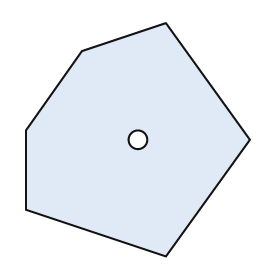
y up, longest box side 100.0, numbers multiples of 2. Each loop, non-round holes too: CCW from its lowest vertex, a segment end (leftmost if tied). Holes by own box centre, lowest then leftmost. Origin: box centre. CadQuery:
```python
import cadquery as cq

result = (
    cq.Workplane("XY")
    .moveTo(12.0, -50.0)
    .lineTo(48.0, 0.0)
    .lineTo(12.0, 50.0)
    .lineTo(-24.0, 38.0)
    .lineTo(-48.0, 4.0)
    .lineTo(-48.0, -30.0)
    .close()
    .moveTo(0.0, 0.0)
    .circle(4.0)
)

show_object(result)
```